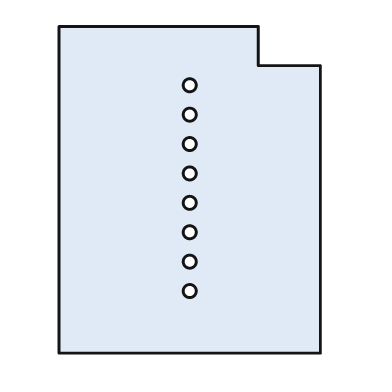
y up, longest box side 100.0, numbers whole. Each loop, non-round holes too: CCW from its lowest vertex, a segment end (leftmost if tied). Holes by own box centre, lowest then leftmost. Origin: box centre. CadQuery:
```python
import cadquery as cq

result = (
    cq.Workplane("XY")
    .moveTo(-40.0, -50.0)
    .lineTo(40.0, -50.0)
    .lineTo(40.0, 38.0)
    .lineTo(21.0, 38.0)
    .lineTo(21.0, 50.0)
    .lineTo(-40.0, 50.0)
    .close()
    .moveTo(0.0, -31.0)
    .circle(2.0)
    .moveTo(0.0, -22.0)
    .circle(2.0)
    .moveTo(0.0, -13.0)
    .circle(2.0)
    .moveTo(0.0, -4.0)
    .circle(2.0)
    .moveTo(0.0, 5.0)
    .circle(2.0)
    .moveTo(0.0, 14.0)
    .circle(2.0)
    .moveTo(0.0, 23.0)
    .circle(2.0)
    .moveTo(0.0, 32.0)
    .circle(2.0)
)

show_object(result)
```